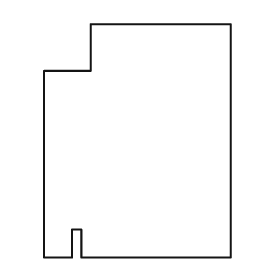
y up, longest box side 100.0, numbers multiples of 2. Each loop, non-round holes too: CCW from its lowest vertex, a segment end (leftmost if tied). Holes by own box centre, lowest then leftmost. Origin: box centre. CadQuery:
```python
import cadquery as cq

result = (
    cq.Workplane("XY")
    .moveTo(-40.0, -50.0)
    .lineTo(-28.0, -50.0)
    .lineTo(-28.0, -38.0)
    .lineTo(-24.0, -38.0)
    .lineTo(-24.0, -50.0)
    .lineTo(40.0, -50.0)
    .lineTo(40.0, 50.0)
    .lineTo(-20.0, 50.0)
    .lineTo(-20.0, 30.0)
    .lineTo(-40.0, 30.0)
    .close()
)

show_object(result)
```